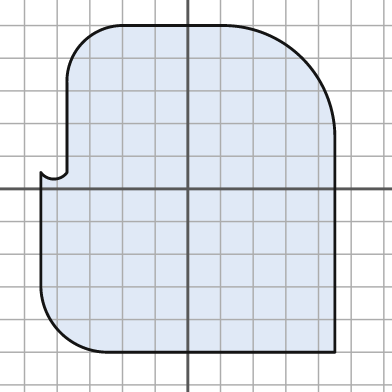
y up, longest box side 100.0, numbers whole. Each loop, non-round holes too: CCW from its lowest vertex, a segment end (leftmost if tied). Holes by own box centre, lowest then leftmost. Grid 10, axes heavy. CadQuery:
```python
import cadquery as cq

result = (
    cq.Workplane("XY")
    .moveTo(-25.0, -50.0)
    .lineTo(45.0, -50.0)
    .lineTo(45.0, 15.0)
    .threePointArc((35.0, 40.0), (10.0, 50.0))
    .lineTo(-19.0, 50.0)
    .threePointArc((-32.0, 45.0), (-37.0, 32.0))
    .lineTo(-37.0, 5.0)
    .threePointArc((-41.0, 3.0), (-45.0, 5.0))
    .lineTo(-45.0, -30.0)
    .threePointArc((-39.0, -44.0), (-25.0, -50.0))
    .close()
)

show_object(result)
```